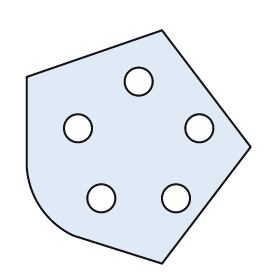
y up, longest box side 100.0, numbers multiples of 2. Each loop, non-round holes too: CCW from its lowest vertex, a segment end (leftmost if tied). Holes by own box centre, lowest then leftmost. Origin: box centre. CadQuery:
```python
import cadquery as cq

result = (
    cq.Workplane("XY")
    .moveTo(10.0, -50.0)
    .lineTo(48.0, 0.0)
    .lineTo(10.0, 50.0)
    .lineTo(-48.0, 30.0)
    .lineTo(-48.0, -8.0)
    .threePointArc((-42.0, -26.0), (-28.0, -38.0))
    .close()
    .moveTo(-16.0, -22.0)
    .circle(6.0)
    .moveTo(16.0, -22.0)
    .circle(6.0)
    .moveTo(-26.0, 8.0)
    .circle(6.0)
    .moveTo(26.0, 8.0)
    .circle(6.0)
    .moveTo(0.0, 28.0)
    .circle(6.0)
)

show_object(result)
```